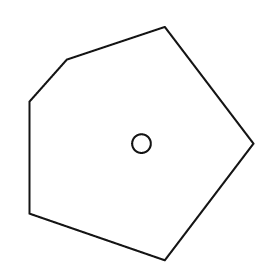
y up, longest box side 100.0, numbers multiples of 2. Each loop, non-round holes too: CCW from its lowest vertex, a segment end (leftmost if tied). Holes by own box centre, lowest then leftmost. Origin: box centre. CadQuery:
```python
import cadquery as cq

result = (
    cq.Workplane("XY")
    .moveTo(10.0, -50.0)
    .lineTo(48.0, 0.0)
    .lineTo(10.0, 50.0)
    .lineTo(-32.0, 36.0)
    .lineTo(-48.0, 18.0)
    .lineTo(-48.0, -30.0)
    .close()
    .moveTo(0.0, 0.0)
    .circle(4.0)
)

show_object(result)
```